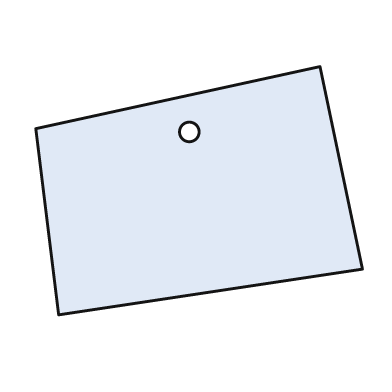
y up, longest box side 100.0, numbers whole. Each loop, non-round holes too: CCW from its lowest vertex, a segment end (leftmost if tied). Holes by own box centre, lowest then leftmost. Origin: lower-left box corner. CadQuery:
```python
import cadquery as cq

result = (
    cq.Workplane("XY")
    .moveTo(7.0, 0.0)
    .lineTo(100.0, 14.0)
    .lineTo(87.0, 76.0)
    .lineTo(0.0, 57.0)
    .close()
    .moveTo(47.0, 56.0)
    .circle(3.0)
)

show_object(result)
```